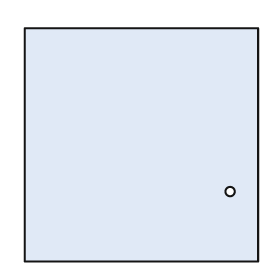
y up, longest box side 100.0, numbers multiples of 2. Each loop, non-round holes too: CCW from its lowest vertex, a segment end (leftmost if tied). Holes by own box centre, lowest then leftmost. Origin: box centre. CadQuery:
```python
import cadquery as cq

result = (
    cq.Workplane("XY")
    .moveTo(-50.0, -50.0)
    .lineTo(50.0, -50.0)
    .lineTo(50.0, 50.0)
    .lineTo(-50.0, 50.0)
    .close()
    .moveTo(38.0, -20.0)
    .circle(2.0)
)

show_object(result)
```